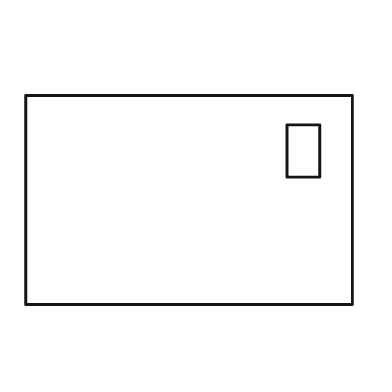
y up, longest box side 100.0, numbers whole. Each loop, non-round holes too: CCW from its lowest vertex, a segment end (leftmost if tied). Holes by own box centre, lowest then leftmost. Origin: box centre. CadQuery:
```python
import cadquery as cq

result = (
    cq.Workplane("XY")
    .moveTo(-50.0, -32.0)
    .lineTo(50.0, -32.0)
    .lineTo(50.0, 32.0)
    .lineTo(-50.0, 32.0)
    .close()
    .moveTo(30.0, 7.0)
    .lineTo(40.0, 7.0)
    .lineTo(40.0, 23.0)
    .lineTo(30.0, 23.0)
    .close()
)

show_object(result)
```